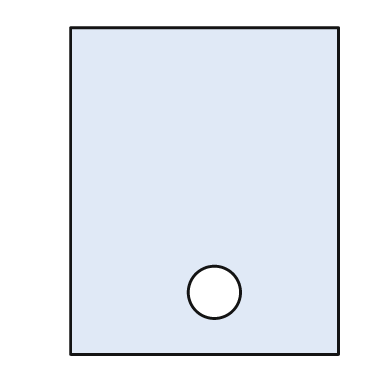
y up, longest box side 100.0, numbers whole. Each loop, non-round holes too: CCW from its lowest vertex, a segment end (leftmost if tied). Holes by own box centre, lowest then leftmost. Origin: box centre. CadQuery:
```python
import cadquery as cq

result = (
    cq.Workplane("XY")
    .moveTo(-41.0, -50.0)
    .lineTo(41.0, -50.0)
    .lineTo(41.0, 50.0)
    .lineTo(-41.0, 50.0)
    .close()
    .moveTo(3.0, -31.0)
    .circle(8.0)
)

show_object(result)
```